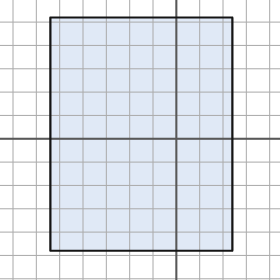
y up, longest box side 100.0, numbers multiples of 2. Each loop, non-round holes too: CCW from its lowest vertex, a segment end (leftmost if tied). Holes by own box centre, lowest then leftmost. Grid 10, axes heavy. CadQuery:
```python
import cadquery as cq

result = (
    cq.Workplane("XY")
    .moveTo(-54.0, -48.0)
    .lineTo(24.0, -48.0)
    .lineTo(24.0, 52.0)
    .lineTo(-54.0, 52.0)
    .close()
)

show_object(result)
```